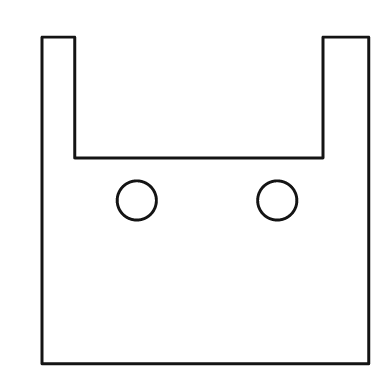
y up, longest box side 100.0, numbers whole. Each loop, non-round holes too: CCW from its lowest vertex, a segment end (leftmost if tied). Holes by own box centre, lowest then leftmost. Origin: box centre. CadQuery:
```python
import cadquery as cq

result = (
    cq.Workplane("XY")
    .moveTo(-50.0, -50.0)
    .lineTo(50.0, -50.0)
    .lineTo(50.0, 50.0)
    .lineTo(36.0, 50.0)
    .lineTo(36.0, 13.0)
    .lineTo(-40.0, 13.0)
    .lineTo(-40.0, 50.0)
    .lineTo(-50.0, 50.0)
    .close()
    .moveTo(-21.0, 0.0)
    .circle(6.0)
    .moveTo(22.0, 0.0)
    .circle(6.0)
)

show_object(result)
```